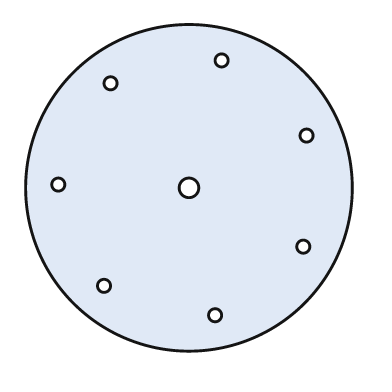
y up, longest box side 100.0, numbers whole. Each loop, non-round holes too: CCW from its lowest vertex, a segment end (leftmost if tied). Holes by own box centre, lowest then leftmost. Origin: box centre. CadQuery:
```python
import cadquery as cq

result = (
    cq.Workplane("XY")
    .moveTo(0.0, 0.0)
    .circle(50.0)
    .moveTo(8.0, -39.0)
    .circle(2.0)
    .moveTo(-26.0, -30.0)
    .circle(2.0)
    .moveTo(35.0, -18.0)
    .circle(2.0)
    .moveTo(0.0, 0.0)
    .circle(3.0)
    .moveTo(-40.0, 1.0)
    .circle(2.0)
    .moveTo(36.0, 16.0)
    .circle(2.0)
    .moveTo(-24.0, 32.0)
    .circle(2.0)
    .moveTo(10.0, 39.0)
    .circle(2.0)
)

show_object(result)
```